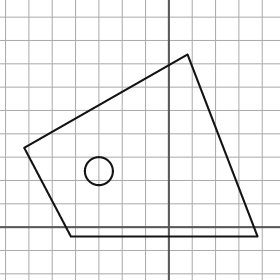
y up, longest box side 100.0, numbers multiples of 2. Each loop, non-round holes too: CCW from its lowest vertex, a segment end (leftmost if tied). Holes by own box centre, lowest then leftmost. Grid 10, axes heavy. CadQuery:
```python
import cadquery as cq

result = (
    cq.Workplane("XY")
    .moveTo(-42.0, -4.0)
    .lineTo(38.0, -4.0)
    .lineTo(8.0, 74.0)
    .lineTo(-62.0, 34.0)
    .close()
    .moveTo(-30.0, 24.0)
    .circle(6.0)
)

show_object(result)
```